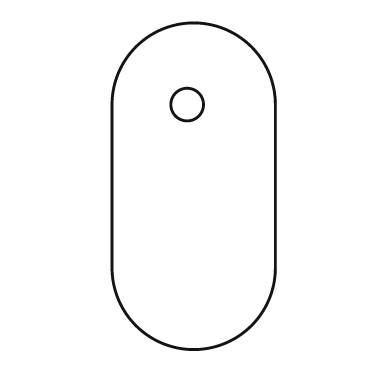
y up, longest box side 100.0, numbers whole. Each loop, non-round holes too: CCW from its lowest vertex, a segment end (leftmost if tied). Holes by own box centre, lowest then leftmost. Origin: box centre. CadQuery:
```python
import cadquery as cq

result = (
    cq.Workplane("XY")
    .moveTo(-25.0, -25.0)
    .threePointArc((0.0, -50.0), (25.0, -25.0))
    .lineTo(25.0, 25.0)
    .threePointArc((0.0, 50.0), (-25.0, 25.0))
    .close()
    .moveTo(-2.0, 25.0)
    .circle(5.0)
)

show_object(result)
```